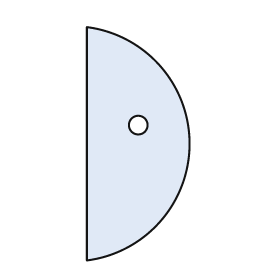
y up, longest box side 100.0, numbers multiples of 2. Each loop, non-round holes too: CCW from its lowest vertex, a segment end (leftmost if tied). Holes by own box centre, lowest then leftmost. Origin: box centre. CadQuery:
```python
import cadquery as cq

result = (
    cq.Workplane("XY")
    .moveTo(-22.0, -50.0)
    .threePointArc((22.0, 0.0), (-22.0, 50.0))
    .close()
    .moveTo(0.0, 8.0)
    .circle(4.0)
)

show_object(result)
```